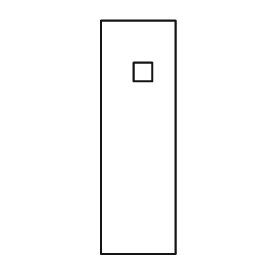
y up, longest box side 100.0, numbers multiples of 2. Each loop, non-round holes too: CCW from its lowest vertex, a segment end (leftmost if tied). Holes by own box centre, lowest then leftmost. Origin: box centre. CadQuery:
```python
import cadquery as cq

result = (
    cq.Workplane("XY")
    .moveTo(-16.0, -50.0)
    .lineTo(16.0, -50.0)
    .lineTo(16.0, 50.0)
    .lineTo(-16.0, 50.0)
    .close()
    .moveTo(-2.0, 24.0)
    .lineTo(6.0, 24.0)
    .lineTo(6.0, 32.0)
    .lineTo(-2.0, 32.0)
    .close()
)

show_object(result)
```